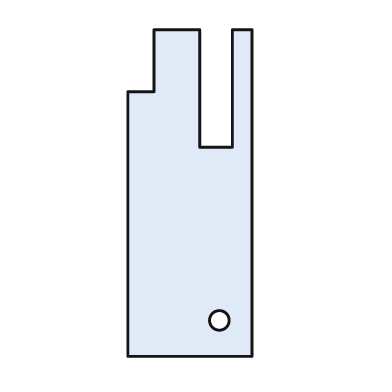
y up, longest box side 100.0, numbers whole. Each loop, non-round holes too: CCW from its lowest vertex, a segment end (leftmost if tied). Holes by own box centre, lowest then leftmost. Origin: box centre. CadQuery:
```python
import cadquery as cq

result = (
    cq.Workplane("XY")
    .moveTo(-19.0, -50.0)
    .lineTo(19.0, -50.0)
    .lineTo(19.0, 50.0)
    .lineTo(13.0, 50.0)
    .lineTo(13.0, 14.0)
    .lineTo(3.0, 14.0)
    .lineTo(3.0, 50.0)
    .lineTo(-11.0, 50.0)
    .lineTo(-11.0, 31.0)
    .lineTo(-19.0, 31.0)
    .close()
    .moveTo(9.0, -39.0)
    .circle(3.0)
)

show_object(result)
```